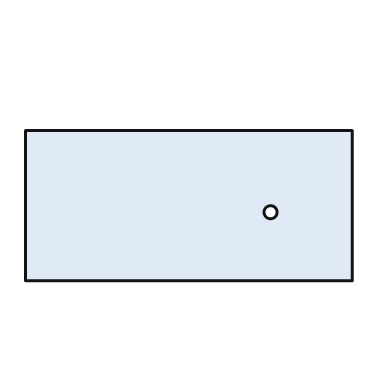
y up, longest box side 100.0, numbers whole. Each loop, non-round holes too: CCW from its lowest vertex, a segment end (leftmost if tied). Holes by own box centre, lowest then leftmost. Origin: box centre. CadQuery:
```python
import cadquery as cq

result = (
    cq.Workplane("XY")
    .moveTo(-50.0, -23.0)
    .lineTo(50.0, -23.0)
    .lineTo(50.0, 23.0)
    .lineTo(-50.0, 23.0)
    .close()
    .moveTo(25.0, -2.0)
    .circle(2.0)
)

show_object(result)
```